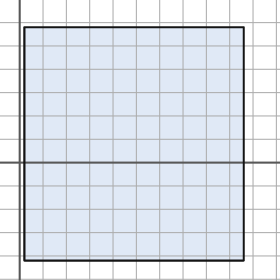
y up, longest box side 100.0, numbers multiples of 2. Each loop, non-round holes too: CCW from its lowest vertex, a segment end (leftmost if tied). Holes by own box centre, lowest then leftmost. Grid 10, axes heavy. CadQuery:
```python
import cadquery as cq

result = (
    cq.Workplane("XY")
    .moveTo(2.0, -42.0)
    .lineTo(96.0, -42.0)
    .lineTo(96.0, 58.0)
    .lineTo(2.0, 58.0)
    .close()
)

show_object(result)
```